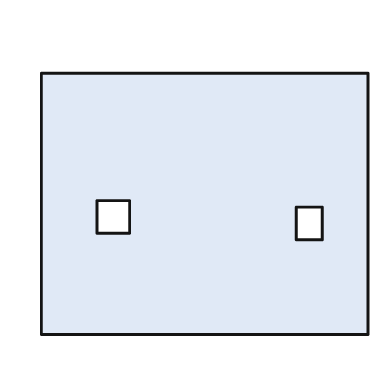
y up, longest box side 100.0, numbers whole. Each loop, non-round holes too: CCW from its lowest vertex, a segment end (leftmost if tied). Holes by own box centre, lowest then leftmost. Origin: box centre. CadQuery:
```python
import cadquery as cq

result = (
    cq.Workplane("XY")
    .moveTo(-50.0, -40.0)
    .lineTo(50.0, -40.0)
    .lineTo(50.0, 40.0)
    .lineTo(-50.0, 40.0)
    .close()
    .moveTo(28.0, -11.0)
    .lineTo(36.0, -11.0)
    .lineTo(36.0, -1.0)
    .lineTo(28.0, -1.0)
    .close()
    .moveTo(-33.0, -9.0)
    .lineTo(-23.0, -9.0)
    .lineTo(-23.0, 1.0)
    .lineTo(-33.0, 1.0)
    .close()
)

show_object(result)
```